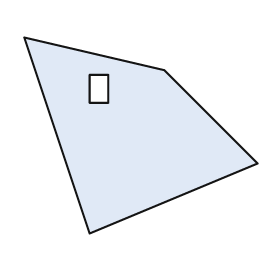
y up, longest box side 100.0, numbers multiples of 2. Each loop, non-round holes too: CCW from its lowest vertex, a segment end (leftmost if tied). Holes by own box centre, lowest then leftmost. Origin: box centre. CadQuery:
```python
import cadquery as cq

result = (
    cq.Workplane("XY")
    .moveTo(-22.0, -42.0)
    .lineTo(50.0, -12.0)
    .lineTo(10.0, 28.0)
    .lineTo(-50.0, 42.0)
    .close()
    .moveTo(-22.0, 14.0)
    .lineTo(-14.0, 14.0)
    .lineTo(-14.0, 26.0)
    .lineTo(-22.0, 26.0)
    .close()
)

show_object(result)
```